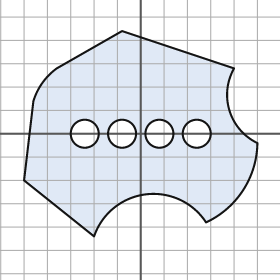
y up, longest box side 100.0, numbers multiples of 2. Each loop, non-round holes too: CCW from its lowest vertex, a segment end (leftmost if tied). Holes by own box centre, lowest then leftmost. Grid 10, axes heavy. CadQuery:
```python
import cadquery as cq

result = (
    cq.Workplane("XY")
    .moveTo(-20.0, -44.0)
    .threePointArc((2.0, -26.0), (28.0, -38.0))
    .threePointArc((44.0, -24.0), (50.0, -4.0))
    .threePointArc((38.0, 10.0), (40.0, 28.0))
    .lineTo(-8.0, 44.0)
    .lineTo(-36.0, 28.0)
    .threePointArc((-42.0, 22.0), (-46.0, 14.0))
    .lineTo(-50.0, -20.0)
    .close()
    .moveTo(-24.0, 0.0)
    .circle(6.0)
    .moveTo(-8.0, 0.0)
    .circle(6.0)
    .moveTo(8.0, 0.0)
    .circle(6.0)
    .moveTo(24.0, 0.0)
    .circle(6.0)
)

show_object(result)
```